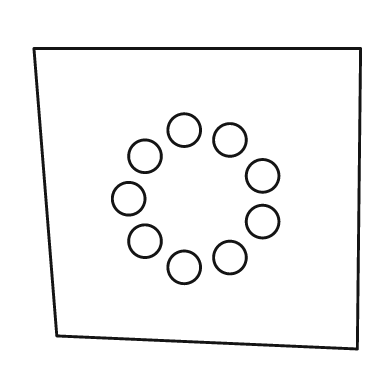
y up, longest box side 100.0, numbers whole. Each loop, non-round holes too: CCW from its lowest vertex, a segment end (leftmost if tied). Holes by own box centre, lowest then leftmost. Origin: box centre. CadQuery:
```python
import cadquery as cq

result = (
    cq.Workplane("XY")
    .moveTo(49.0, -46.0)
    .lineTo(50.0, 46.0)
    .lineTo(-50.0, 46.0)
    .lineTo(-43.0, -42.0)
    .close()
    .moveTo(-4.0, -21.0)
    .circle(5.0)
    .moveTo(10.0, -18.0)
    .circle(5.0)
    .moveTo(-16.0, -13.0)
    .circle(5.0)
    .moveTo(20.0, -7.0)
    .circle(5.0)
    .moveTo(-21.0, 0.0)
    .circle(5.0)
    .moveTo(20.0, 7.0)
    .circle(5.0)
    .moveTo(-16.0, 13.0)
    .circle(5.0)
    .moveTo(10.0, 18.0)
    .circle(5.0)
    .moveTo(-4.0, 21.0)
    .circle(5.0)
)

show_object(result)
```